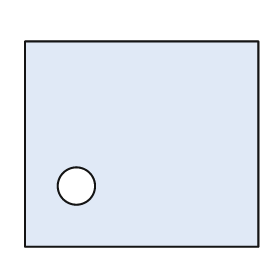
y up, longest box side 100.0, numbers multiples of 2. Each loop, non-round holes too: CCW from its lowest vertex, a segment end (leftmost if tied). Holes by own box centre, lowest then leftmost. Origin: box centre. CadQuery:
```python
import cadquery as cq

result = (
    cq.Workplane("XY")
    .moveTo(-50.0, -44.0)
    .lineTo(50.0, -44.0)
    .lineTo(50.0, 44.0)
    .lineTo(-50.0, 44.0)
    .close()
    .moveTo(-28.0, -18.0)
    .circle(8.0)
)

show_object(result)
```